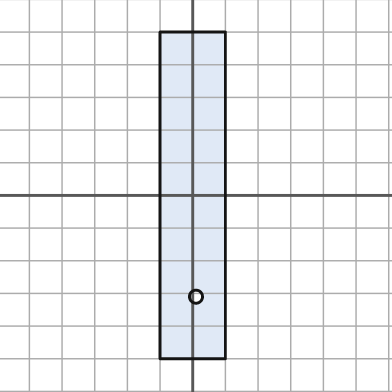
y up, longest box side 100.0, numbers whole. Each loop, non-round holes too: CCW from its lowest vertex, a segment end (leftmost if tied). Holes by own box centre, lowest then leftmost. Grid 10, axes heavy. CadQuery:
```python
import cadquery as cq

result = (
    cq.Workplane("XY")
    .moveTo(-10.0, -50.0)
    .lineTo(10.0, -50.0)
    .lineTo(10.0, 50.0)
    .lineTo(-10.0, 50.0)
    .close()
    .moveTo(1.0, -31.0)
    .circle(2.0)
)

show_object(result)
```